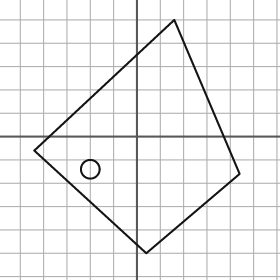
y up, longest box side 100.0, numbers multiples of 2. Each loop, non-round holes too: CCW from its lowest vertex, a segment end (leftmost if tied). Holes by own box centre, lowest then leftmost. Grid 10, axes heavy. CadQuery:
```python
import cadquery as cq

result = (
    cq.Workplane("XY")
    .moveTo(4.0, -50.0)
    .lineTo(44.0, -16.0)
    .lineTo(16.0, 50.0)
    .lineTo(-44.0, -6.0)
    .close()
    .moveTo(-20.0, -14.0)
    .circle(4.0)
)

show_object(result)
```